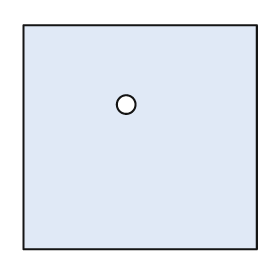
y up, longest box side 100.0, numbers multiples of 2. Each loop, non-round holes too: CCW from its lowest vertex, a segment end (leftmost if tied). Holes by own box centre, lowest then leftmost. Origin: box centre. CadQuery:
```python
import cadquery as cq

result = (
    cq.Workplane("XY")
    .moveTo(-50.0, -48.0)
    .lineTo(50.0, -48.0)
    .lineTo(50.0, 48.0)
    .lineTo(-50.0, 48.0)
    .close()
    .moveTo(-6.0, 14.0)
    .circle(4.0)
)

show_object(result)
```